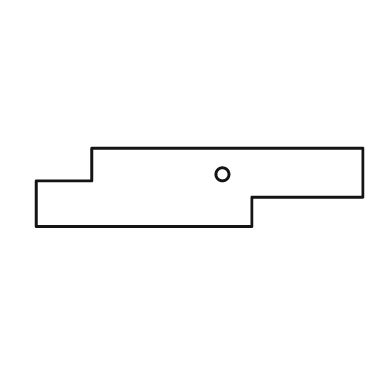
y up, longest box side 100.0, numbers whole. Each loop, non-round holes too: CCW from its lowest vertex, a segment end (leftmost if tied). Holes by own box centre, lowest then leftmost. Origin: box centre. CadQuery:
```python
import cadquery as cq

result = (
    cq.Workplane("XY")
    .moveTo(-50.0, -12.0)
    .lineTo(16.0, -12.0)
    .lineTo(16.0, -3.0)
    .lineTo(50.0, -3.0)
    .lineTo(50.0, 12.0)
    .lineTo(-33.0, 12.0)
    .lineTo(-33.0, 2.0)
    .lineTo(-50.0, 2.0)
    .close()
    .moveTo(7.0, 4.0)
    .circle(2.0)
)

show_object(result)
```